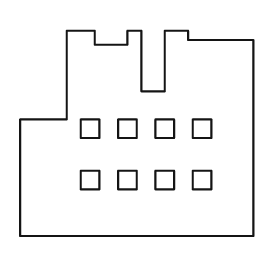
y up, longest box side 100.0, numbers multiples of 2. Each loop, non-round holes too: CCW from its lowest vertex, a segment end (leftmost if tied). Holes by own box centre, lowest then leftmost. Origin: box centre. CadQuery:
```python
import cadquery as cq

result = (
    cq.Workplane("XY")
    .moveTo(-50.0, -44.0)
    .lineTo(50.0, -44.0)
    .lineTo(50.0, 40.0)
    .lineTo(22.0, 40.0)
    .lineTo(22.0, 44.0)
    .lineTo(12.0, 44.0)
    .lineTo(12.0, 18.0)
    .lineTo(2.0, 18.0)
    .lineTo(2.0, 44.0)
    .lineTo(-4.0, 44.0)
    .lineTo(-4.0, 38.0)
    .lineTo(-18.0, 38.0)
    .lineTo(-18.0, 44.0)
    .lineTo(-30.0, 44.0)
    .lineTo(-30.0, 6.0)
    .lineTo(-50.0, 6.0)
    .close()
    .moveTo(-24.0, -24.0)
    .lineTo(-16.0, -24.0)
    .lineTo(-16.0, -16.0)
    .lineTo(-24.0, -16.0)
    .close()
    .moveTo(-8.0, -24.0)
    .lineTo(0.0, -24.0)
    .lineTo(0.0, -16.0)
    .lineTo(-8.0, -16.0)
    .close()
    .moveTo(8.0, -24.0)
    .lineTo(16.0, -24.0)
    .lineTo(16.0, -16.0)
    .lineTo(8.0, -16.0)
    .close()
    .moveTo(24.0, -24.0)
    .lineTo(32.0, -24.0)
    .lineTo(32.0, -16.0)
    .lineTo(24.0, -16.0)
    .close()
    .moveTo(-24.0, -2.0)
    .lineTo(-16.0, -2.0)
    .lineTo(-16.0, 6.0)
    .lineTo(-24.0, 6.0)
    .close()
    .moveTo(-8.0, -2.0)
    .lineTo(0.0, -2.0)
    .lineTo(0.0, 6.0)
    .lineTo(-8.0, 6.0)
    .close()
    .moveTo(8.0, -2.0)
    .lineTo(16.0, -2.0)
    .lineTo(16.0, 6.0)
    .lineTo(8.0, 6.0)
    .close()
    .moveTo(24.0, -2.0)
    .lineTo(32.0, -2.0)
    .lineTo(32.0, 6.0)
    .lineTo(24.0, 6.0)
    .close()
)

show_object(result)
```